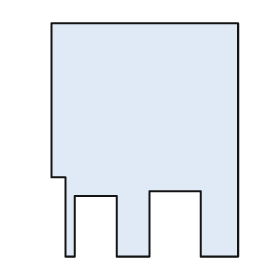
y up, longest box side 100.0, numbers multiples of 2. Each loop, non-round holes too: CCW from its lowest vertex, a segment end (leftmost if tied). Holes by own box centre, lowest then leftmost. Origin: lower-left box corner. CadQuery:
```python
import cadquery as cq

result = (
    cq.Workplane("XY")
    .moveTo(6.0, 0.0)
    .lineTo(10.0, 0.0)
    .lineTo(10.0, 26.0)
    .lineTo(28.0, 26.0)
    .lineTo(28.0, 0.0)
    .lineTo(42.0, 0.0)
    .lineTo(42.0, 28.0)
    .lineTo(64.0, 28.0)
    .lineTo(64.0, 0.0)
    .lineTo(80.0, 0.0)
    .lineTo(80.0, 100.0)
    .lineTo(0.0, 100.0)
    .lineTo(0.0, 34.0)
    .lineTo(6.0, 34.0)
    .close()
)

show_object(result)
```